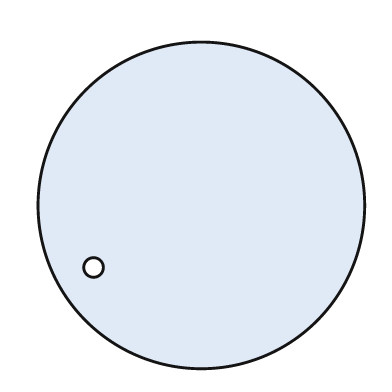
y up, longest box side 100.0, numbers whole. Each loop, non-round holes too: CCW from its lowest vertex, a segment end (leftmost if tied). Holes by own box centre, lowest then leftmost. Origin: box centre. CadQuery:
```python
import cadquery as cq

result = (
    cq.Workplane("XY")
    .moveTo(0.0, 0.0)
    .circle(50.0)
    .moveTo(-33.0, -19.0)
    .circle(3.0)
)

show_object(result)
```